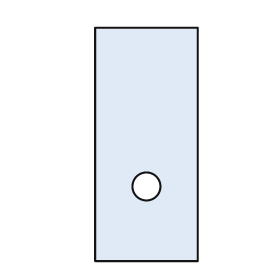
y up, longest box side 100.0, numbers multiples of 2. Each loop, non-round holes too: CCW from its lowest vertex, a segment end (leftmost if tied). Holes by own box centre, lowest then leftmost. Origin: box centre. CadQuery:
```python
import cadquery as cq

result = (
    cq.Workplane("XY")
    .moveTo(-22.0, -50.0)
    .lineTo(22.0, -50.0)
    .lineTo(22.0, 50.0)
    .lineTo(-22.0, 50.0)
    .close()
    .moveTo(0.0, -18.0)
    .circle(6.0)
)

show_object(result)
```